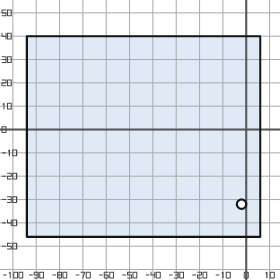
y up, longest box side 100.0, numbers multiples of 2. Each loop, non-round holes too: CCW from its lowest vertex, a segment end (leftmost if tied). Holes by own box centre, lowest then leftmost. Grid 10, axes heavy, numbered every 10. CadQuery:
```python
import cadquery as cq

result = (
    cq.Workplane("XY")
    .moveTo(-94.0, -46.0)
    .lineTo(6.0, -46.0)
    .lineTo(6.0, 40.0)
    .lineTo(-94.0, 40.0)
    .close()
    .moveTo(-2.0, -32.0)
    .circle(2.0)
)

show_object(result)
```